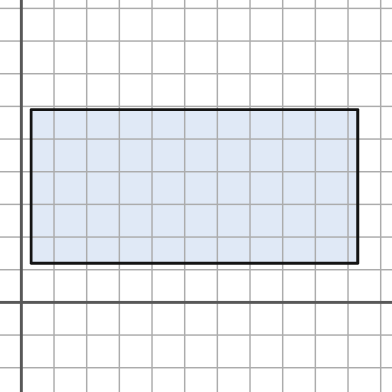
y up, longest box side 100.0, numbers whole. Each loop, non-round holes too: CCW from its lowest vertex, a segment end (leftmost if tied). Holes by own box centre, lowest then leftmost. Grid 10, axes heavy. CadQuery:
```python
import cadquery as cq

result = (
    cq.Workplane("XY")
    .moveTo(3.0, 12.0)
    .lineTo(103.0, 12.0)
    .lineTo(103.0, 59.0)
    .lineTo(3.0, 59.0)
    .close()
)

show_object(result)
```